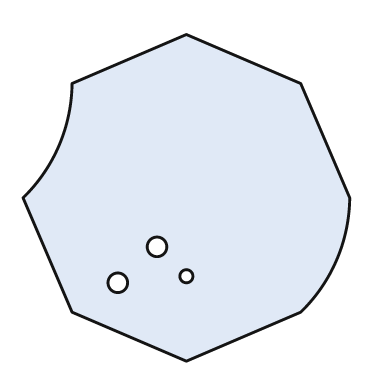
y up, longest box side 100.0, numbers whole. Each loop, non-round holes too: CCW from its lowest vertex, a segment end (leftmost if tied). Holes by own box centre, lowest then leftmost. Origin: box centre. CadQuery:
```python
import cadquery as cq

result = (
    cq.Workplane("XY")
    .moveTo(0.0, -50.0)
    .lineTo(35.0, -35.0)
    .threePointArc((46.0, -19.0), (50.0, 0.0))
    .lineTo(35.0, 35.0)
    .lineTo(0.0, 50.0)
    .lineTo(-35.0, 35.0)
    .threePointArc((-39.0, 16.0), (-50.0, 0.0))
    .lineTo(-35.0, -35.0)
    .close()
    .moveTo(-21.0, -26.0)
    .circle(3.0)
    .moveTo(0.0, -24.0)
    .circle(2.0)
    .moveTo(-9.0, -15.0)
    .circle(3.0)
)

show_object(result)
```